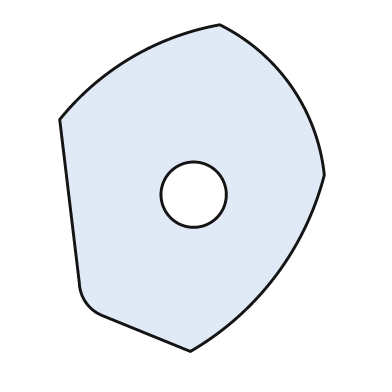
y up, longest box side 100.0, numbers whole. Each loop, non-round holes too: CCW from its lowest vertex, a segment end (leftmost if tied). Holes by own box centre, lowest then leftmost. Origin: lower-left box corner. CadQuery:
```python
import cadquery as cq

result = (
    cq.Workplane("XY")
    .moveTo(40.0, 0.0)
    .threePointArc((66.0, 23.0), (81.0, 54.0))
    .threePointArc((71.0, 81.0), (49.0, 100.0))
    .threePointArc((22.0, 90.0), (0.0, 71.0))
    .lineTo(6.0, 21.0)
    .threePointArc((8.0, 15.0), (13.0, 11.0))
    .close()
    .moveTo(41.0, 48.0)
    .circle(10.0)
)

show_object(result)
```